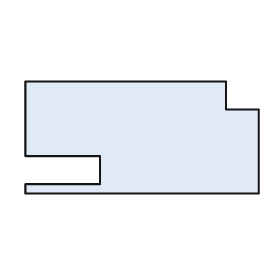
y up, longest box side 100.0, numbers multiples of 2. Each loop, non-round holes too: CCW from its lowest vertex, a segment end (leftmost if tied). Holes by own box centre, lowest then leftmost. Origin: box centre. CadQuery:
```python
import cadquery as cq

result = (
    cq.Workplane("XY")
    .moveTo(-50.0, -24.0)
    .lineTo(50.0, -24.0)
    .lineTo(50.0, 12.0)
    .lineTo(36.0, 12.0)
    .lineTo(36.0, 24.0)
    .lineTo(-50.0, 24.0)
    .lineTo(-50.0, -8.0)
    .lineTo(-18.0, -8.0)
    .lineTo(-18.0, -20.0)
    .lineTo(-50.0, -20.0)
    .close()
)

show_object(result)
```